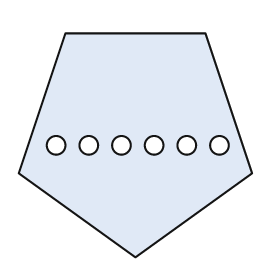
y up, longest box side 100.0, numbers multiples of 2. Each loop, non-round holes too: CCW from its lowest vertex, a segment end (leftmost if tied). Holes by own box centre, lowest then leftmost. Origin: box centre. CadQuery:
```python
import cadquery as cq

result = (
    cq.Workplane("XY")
    .moveTo(0.0, -48.0)
    .lineTo(50.0, -12.0)
    .lineTo(30.0, 48.0)
    .lineTo(-30.0, 48.0)
    .lineTo(-50.0, -12.0)
    .close()
    .moveTo(-34.0, 0.0)
    .circle(4.0)
    .moveTo(-20.0, 0.0)
    .circle(4.0)
    .moveTo(-6.0, 0.0)
    .circle(4.0)
    .moveTo(8.0, 0.0)
    .circle(4.0)
    .moveTo(22.0, 0.0)
    .circle(4.0)
    .moveTo(36.0, 0.0)
    .circle(4.0)
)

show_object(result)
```